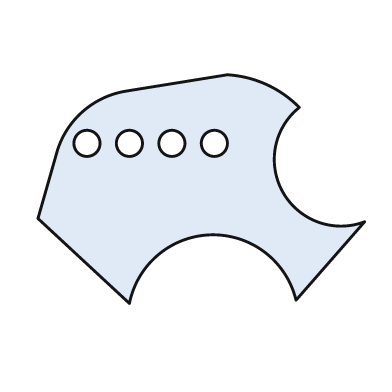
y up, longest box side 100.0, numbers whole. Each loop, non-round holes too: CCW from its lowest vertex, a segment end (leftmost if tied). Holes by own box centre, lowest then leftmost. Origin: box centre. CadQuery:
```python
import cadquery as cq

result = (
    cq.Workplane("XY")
    .moveTo(-22.0, -35.0)
    .threePointArc((3.0, -14.0), (29.0, -34.0))
    .lineTo(50.0, -10.0)
    .threePointArc((25.0, -1.0), (30.0, 25.0))
    .threePointArc((20.0, 32.0), (8.0, 35.0))
    .lineTo(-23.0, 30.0)
    .threePointArc((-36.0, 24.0), (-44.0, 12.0))
    .lineTo(-50.0, -9.0)
    .close()
    .moveTo(-35.0, 14.0)
    .circle(4.0)
    .moveTo(-22.0, 14.0)
    .circle(4.0)
    .moveTo(-9.0, 14.0)
    .circle(4.0)
    .moveTo(4.0, 14.0)
    .circle(4.0)
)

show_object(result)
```